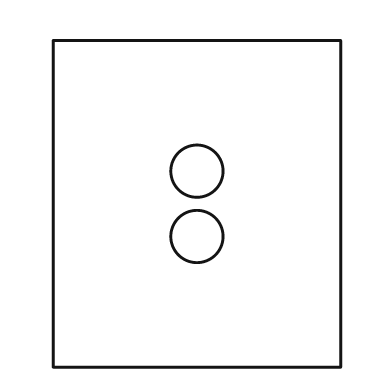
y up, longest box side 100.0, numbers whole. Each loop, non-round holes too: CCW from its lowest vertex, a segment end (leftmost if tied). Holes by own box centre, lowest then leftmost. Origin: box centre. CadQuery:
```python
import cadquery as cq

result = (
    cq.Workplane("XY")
    .moveTo(-44.0, -50.0)
    .lineTo(44.0, -50.0)
    .lineTo(44.0, 50.0)
    .lineTo(-44.0, 50.0)
    .close()
    .moveTo(0.0, -10.0)
    .circle(8.0)
    .moveTo(0.0, 10.0)
    .circle(8.0)
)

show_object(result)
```